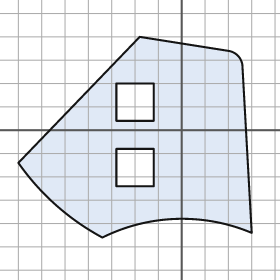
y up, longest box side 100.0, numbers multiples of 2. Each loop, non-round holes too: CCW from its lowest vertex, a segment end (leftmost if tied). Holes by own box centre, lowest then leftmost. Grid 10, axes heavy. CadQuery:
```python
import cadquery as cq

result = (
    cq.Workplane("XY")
    .moveTo(-34.0, -46.0)
    .threePointArc((-2.0, -38.0), (30.0, -44.0))
    .lineTo(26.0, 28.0)
    .threePointArc((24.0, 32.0), (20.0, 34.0))
    .lineTo(-18.0, 40.0)
    .lineTo(-70.0, -14.0)
    .threePointArc((-54.0, -32.0), (-34.0, -46.0))
    .close()
    .moveTo(-28.0, -24.0)
    .lineTo(-12.0, -24.0)
    .lineTo(-12.0, -8.0)
    .lineTo(-28.0, -8.0)
    .close()
    .moveTo(-28.0, 4.0)
    .lineTo(-12.0, 4.0)
    .lineTo(-12.0, 20.0)
    .lineTo(-28.0, 20.0)
    .close()
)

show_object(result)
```